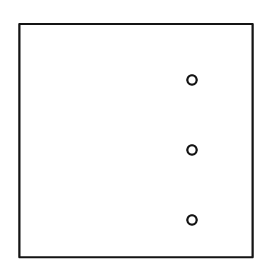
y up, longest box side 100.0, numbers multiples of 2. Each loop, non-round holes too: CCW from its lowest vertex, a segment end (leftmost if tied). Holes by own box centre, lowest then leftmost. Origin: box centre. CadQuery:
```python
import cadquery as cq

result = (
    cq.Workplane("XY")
    .moveTo(-50.0, -50.0)
    .lineTo(50.0, -50.0)
    .lineTo(50.0, 50.0)
    .lineTo(-50.0, 50.0)
    .close()
    .moveTo(24.0, -34.0)
    .circle(2.0)
    .moveTo(24.0, -4.0)
    .circle(2.0)
    .moveTo(24.0, 26.0)
    .circle(2.0)
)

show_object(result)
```